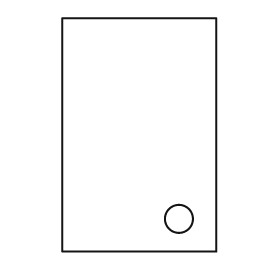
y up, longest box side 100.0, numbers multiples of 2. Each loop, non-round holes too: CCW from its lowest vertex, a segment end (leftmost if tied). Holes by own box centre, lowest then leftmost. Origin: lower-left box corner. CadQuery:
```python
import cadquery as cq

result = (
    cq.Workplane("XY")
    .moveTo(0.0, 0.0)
    .lineTo(66.0, 0.0)
    .lineTo(66.0, 100.0)
    .lineTo(0.0, 100.0)
    .close()
    .moveTo(50.0, 14.0)
    .circle(6.0)
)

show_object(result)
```